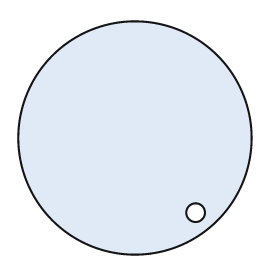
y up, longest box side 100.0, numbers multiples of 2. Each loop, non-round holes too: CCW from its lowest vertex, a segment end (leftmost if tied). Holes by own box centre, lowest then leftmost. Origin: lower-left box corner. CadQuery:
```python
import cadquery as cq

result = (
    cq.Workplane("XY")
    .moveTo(50.0, 50.0)
    .circle(50.0)
    .moveTo(76.0, 18.0)
    .circle(4.0)
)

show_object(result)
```